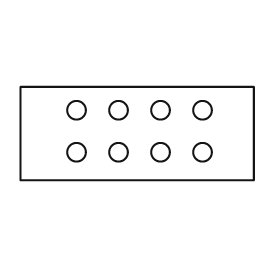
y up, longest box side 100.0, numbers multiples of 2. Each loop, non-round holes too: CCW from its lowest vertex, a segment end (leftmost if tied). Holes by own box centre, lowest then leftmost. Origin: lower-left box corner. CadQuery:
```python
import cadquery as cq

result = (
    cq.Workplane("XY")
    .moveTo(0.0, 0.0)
    .lineTo(100.0, 0.0)
    .lineTo(100.0, 40.0)
    .lineTo(0.0, 40.0)
    .close()
    .moveTo(24.0, 12.0)
    .circle(4.0)
    .moveTo(42.0, 12.0)
    .circle(4.0)
    .moveTo(60.0, 12.0)
    .circle(4.0)
    .moveTo(78.0, 12.0)
    .circle(4.0)
    .moveTo(24.0, 30.0)
    .circle(4.0)
    .moveTo(42.0, 30.0)
    .circle(4.0)
    .moveTo(60.0, 30.0)
    .circle(4.0)
    .moveTo(78.0, 30.0)
    .circle(4.0)
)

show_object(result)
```